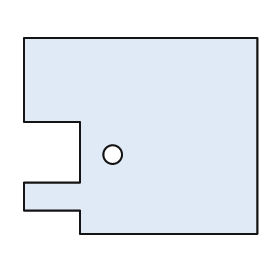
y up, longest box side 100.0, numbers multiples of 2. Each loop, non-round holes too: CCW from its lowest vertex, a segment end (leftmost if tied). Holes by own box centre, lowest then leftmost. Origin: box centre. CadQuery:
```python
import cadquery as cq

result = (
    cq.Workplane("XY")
    .moveTo(-26.0, -42.0)
    .lineTo(50.0, -42.0)
    .lineTo(50.0, 42.0)
    .lineTo(-50.0, 42.0)
    .lineTo(-50.0, 6.0)
    .lineTo(-26.0, 6.0)
    .lineTo(-26.0, -20.0)
    .lineTo(-50.0, -20.0)
    .lineTo(-50.0, -32.0)
    .lineTo(-26.0, -32.0)
    .close()
    .moveTo(-12.0, -8.0)
    .circle(4.0)
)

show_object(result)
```